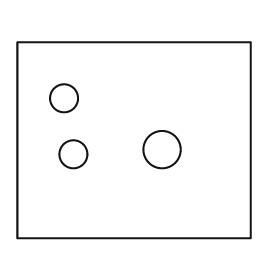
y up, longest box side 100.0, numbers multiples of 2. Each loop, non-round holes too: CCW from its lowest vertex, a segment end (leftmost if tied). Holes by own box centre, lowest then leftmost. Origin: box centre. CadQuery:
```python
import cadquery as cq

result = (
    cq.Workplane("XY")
    .moveTo(-50.0, -42.0)
    .lineTo(50.0, -42.0)
    .lineTo(50.0, 42.0)
    .lineTo(-50.0, 42.0)
    .close()
    .moveTo(-26.0, -6.0)
    .circle(6.0)
    .moveTo(12.0, -4.0)
    .circle(8.0)
    .moveTo(-30.0, 18.0)
    .circle(6.0)
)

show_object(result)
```